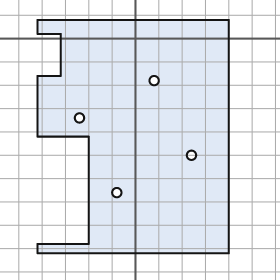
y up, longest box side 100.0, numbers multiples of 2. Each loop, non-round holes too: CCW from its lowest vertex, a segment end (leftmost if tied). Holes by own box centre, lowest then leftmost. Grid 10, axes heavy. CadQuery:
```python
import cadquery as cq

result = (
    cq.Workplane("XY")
    .moveTo(-42.0, -92.0)
    .lineTo(40.0, -92.0)
    .lineTo(40.0, 8.0)
    .lineTo(-42.0, 8.0)
    .lineTo(-42.0, 2.0)
    .lineTo(-32.0, 2.0)
    .lineTo(-32.0, -16.0)
    .lineTo(-42.0, -16.0)
    .lineTo(-42.0, -42.0)
    .lineTo(-20.0, -42.0)
    .lineTo(-20.0, -88.0)
    .lineTo(-42.0, -88.0)
    .close()
    .moveTo(-8.0, -66.0)
    .circle(2.0)
    .moveTo(24.0, -50.0)
    .circle(2.0)
    .moveTo(-24.0, -34.0)
    .circle(2.0)
    .moveTo(8.0, -18.0)
    .circle(2.0)
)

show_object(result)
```